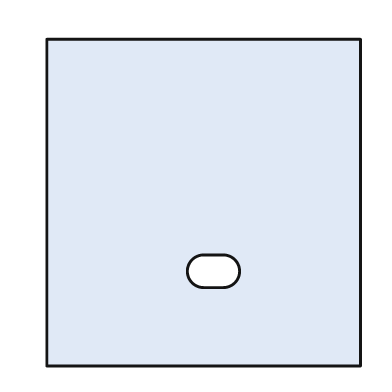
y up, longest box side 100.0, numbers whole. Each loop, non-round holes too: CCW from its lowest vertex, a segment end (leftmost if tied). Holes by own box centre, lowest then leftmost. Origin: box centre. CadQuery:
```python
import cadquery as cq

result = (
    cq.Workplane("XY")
    .moveTo(-48.0, -50.0)
    .lineTo(48.0, -50.0)
    .lineTo(48.0, 50.0)
    .lineTo(-48.0, 50.0)
    .close()
    .moveTo(0.0, -26.0)
    .lineTo(6.0, -26.0)
    .threePointArc((11.0, -21.0), (6.0, -16.0))
    .lineTo(0.0, -16.0)
    .threePointArc((-5.0, -21.0), (0.0, -26.0))
    .close()
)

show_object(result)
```